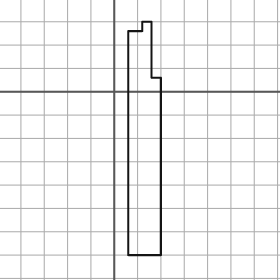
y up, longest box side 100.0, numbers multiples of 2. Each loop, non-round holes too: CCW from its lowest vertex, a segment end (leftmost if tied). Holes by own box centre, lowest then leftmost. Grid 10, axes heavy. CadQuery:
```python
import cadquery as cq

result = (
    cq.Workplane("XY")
    .moveTo(6.0, -70.0)
    .lineTo(20.0, -70.0)
    .lineTo(20.0, 6.0)
    .lineTo(16.0, 6.0)
    .lineTo(16.0, 30.0)
    .lineTo(12.0, 30.0)
    .lineTo(12.0, 26.0)
    .lineTo(6.0, 26.0)
    .close()
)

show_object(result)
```